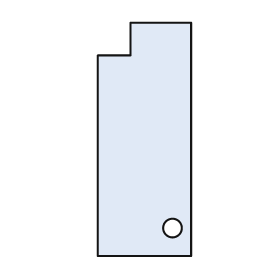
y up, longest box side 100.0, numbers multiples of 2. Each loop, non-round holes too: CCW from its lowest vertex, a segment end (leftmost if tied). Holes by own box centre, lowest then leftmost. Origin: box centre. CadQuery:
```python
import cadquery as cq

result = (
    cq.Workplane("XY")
    .moveTo(-20.0, -50.0)
    .lineTo(20.0, -50.0)
    .lineTo(20.0, 50.0)
    .lineTo(-6.0, 50.0)
    .lineTo(-6.0, 36.0)
    .lineTo(-20.0, 36.0)
    .close()
    .moveTo(12.0, -38.0)
    .circle(4.0)
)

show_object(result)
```